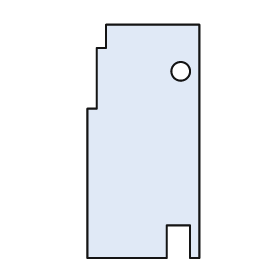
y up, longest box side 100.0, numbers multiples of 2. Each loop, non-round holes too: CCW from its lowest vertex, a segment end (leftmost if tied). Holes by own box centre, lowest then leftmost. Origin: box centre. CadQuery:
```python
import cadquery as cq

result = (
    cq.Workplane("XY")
    .moveTo(-24.0, -50.0)
    .lineTo(10.0, -50.0)
    .lineTo(10.0, -36.0)
    .lineTo(20.0, -36.0)
    .lineTo(20.0, -50.0)
    .lineTo(24.0, -50.0)
    .lineTo(24.0, 50.0)
    .lineTo(-16.0, 50.0)
    .lineTo(-16.0, 40.0)
    .lineTo(-20.0, 40.0)
    .lineTo(-20.0, 14.0)
    .lineTo(-24.0, 14.0)
    .close()
    .moveTo(16.0, 30.0)
    .circle(4.0)
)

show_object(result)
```